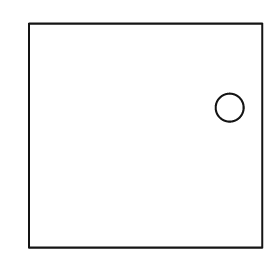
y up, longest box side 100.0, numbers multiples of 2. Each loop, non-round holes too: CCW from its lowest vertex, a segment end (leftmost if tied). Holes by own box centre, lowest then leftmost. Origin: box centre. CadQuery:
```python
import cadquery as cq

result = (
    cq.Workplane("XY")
    .moveTo(-50.0, -48.0)
    .lineTo(50.0, -48.0)
    .lineTo(50.0, 48.0)
    .lineTo(-50.0, 48.0)
    .close()
    .moveTo(36.0, 12.0)
    .circle(6.0)
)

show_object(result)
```